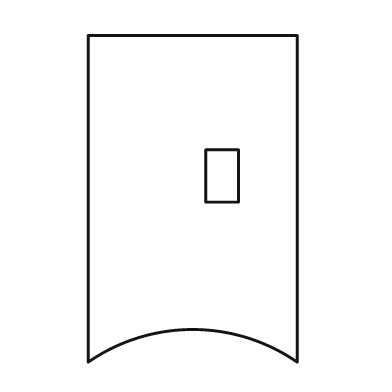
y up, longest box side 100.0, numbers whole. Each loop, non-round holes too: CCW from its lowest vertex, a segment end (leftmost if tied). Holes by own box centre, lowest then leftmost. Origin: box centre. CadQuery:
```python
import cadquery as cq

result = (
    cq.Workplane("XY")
    .moveTo(-32.0, -50.0)
    .threePointArc((0.0, -40.0), (32.0, -50.0))
    .lineTo(32.0, 50.0)
    .lineTo(-32.0, 50.0)
    .close()
    .moveTo(4.0, -1.0)
    .lineTo(14.0, -1.0)
    .lineTo(14.0, 15.0)
    .lineTo(4.0, 15.0)
    .close()
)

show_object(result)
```